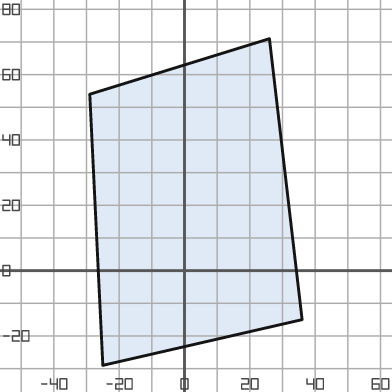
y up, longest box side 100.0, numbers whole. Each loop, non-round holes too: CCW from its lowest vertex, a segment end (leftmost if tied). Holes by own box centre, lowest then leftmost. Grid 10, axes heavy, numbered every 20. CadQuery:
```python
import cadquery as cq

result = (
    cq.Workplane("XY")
    .moveTo(-25.0, -29.0)
    .lineTo(36.0, -15.0)
    .lineTo(26.0, 71.0)
    .lineTo(-29.0, 54.0)
    .close()
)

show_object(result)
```